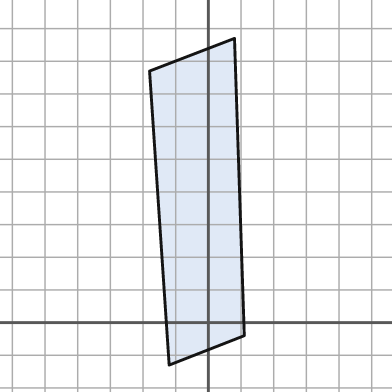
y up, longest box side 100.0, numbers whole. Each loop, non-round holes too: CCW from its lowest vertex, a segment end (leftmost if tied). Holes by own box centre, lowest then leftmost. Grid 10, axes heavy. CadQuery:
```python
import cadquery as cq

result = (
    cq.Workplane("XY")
    .moveTo(-12.0, -13.0)
    .lineTo(11.0, -4.0)
    .lineTo(8.0, 87.0)
    .lineTo(-18.0, 77.0)
    .close()
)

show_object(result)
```